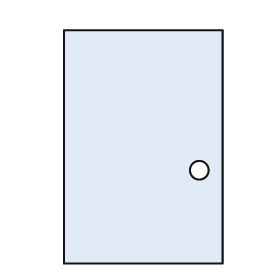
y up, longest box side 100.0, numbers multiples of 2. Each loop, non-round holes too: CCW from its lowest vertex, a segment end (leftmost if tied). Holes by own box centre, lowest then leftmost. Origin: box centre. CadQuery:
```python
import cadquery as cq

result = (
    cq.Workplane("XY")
    .moveTo(-34.0, -50.0)
    .lineTo(34.0, -50.0)
    .lineTo(34.0, 50.0)
    .lineTo(-34.0, 50.0)
    .close()
    .moveTo(24.0, -10.0)
    .circle(4.0)
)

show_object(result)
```